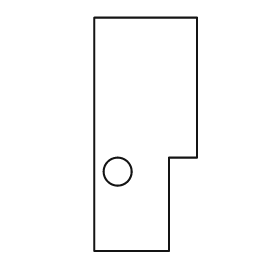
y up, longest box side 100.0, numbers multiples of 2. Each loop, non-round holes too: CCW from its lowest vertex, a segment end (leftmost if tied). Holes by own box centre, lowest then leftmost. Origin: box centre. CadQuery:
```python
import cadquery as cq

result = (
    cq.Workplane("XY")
    .moveTo(-22.0, -50.0)
    .lineTo(10.0, -50.0)
    .lineTo(10.0, -10.0)
    .lineTo(22.0, -10.0)
    .lineTo(22.0, 50.0)
    .lineTo(-22.0, 50.0)
    .close()
    .moveTo(-12.0, -16.0)
    .circle(6.0)
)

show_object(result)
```